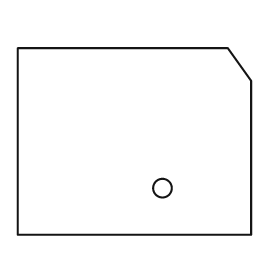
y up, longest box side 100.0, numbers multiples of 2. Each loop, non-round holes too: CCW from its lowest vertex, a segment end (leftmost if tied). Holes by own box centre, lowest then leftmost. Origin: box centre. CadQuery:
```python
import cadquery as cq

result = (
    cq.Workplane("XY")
    .moveTo(-50.0, -40.0)
    .lineTo(50.0, -40.0)
    .lineTo(50.0, 26.0)
    .lineTo(40.0, 40.0)
    .lineTo(-50.0, 40.0)
    .close()
    .moveTo(12.0, -20.0)
    .circle(4.0)
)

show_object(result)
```